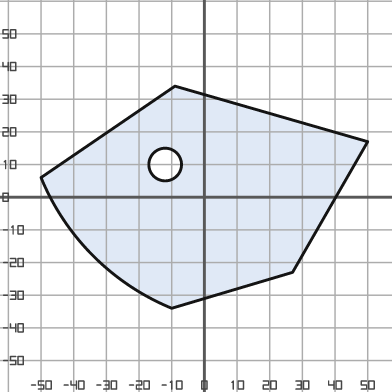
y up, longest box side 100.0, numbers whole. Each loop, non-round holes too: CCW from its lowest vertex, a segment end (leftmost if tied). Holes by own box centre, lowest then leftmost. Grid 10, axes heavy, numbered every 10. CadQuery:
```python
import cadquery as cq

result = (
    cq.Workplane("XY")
    .moveTo(-10.0, -34.0)
    .lineTo(27.0, -23.0)
    .lineTo(50.0, 17.0)
    .lineTo(-9.0, 34.0)
    .lineTo(-50.0, 6.0)
    .threePointArc((-34.0, -18.0), (-10.0, -34.0))
    .close()
    .moveTo(-12.0, 10.0)
    .circle(5.0)
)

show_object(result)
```